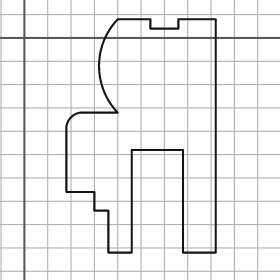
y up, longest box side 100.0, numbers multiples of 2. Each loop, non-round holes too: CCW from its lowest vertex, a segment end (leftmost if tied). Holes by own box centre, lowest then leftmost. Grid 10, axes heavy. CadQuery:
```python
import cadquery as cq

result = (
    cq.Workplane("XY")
    .moveTo(36.0, -92.0)
    .lineTo(46.0, -92.0)
    .lineTo(46.0, -48.0)
    .lineTo(68.0, -48.0)
    .lineTo(68.0, -92.0)
    .lineTo(82.0, -92.0)
    .lineTo(82.0, 8.0)
    .lineTo(66.0, 8.0)
    .lineTo(66.0, 4.0)
    .lineTo(54.0, 4.0)
    .lineTo(54.0, 8.0)
    .lineTo(40.0, 8.0)
    .threePointArc((32.0, -12.0), (40.0, -32.0))
    .lineTo(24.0, -32.0)
    .threePointArc((20.0, -34.0), (18.0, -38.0))
    .lineTo(18.0, -66.0)
    .lineTo(30.0, -66.0)
    .lineTo(30.0, -74.0)
    .lineTo(36.0, -74.0)
    .close()
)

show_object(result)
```